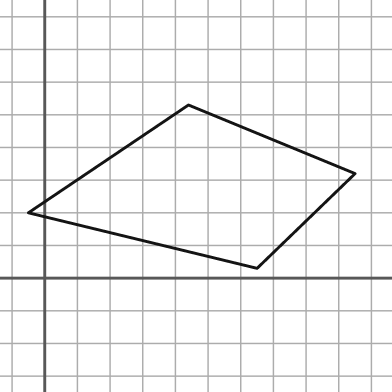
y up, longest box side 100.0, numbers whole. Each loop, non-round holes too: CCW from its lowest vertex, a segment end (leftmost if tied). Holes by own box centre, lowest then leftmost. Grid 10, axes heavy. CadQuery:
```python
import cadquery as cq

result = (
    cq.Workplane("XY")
    .moveTo(65.0, 3.0)
    .lineTo(95.0, 32.0)
    .lineTo(44.0, 53.0)
    .lineTo(-5.0, 20.0)
    .close()
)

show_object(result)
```